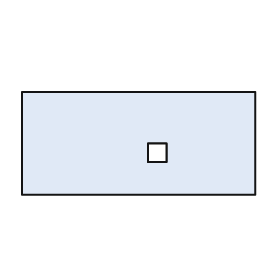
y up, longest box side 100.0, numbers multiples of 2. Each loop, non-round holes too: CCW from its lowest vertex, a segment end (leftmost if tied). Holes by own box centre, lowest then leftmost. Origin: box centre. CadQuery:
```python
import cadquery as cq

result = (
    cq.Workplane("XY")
    .moveTo(-50.0, -22.0)
    .lineTo(50.0, -22.0)
    .lineTo(50.0, 22.0)
    .lineTo(-50.0, 22.0)
    .close()
    .moveTo(4.0, -8.0)
    .lineTo(12.0, -8.0)
    .lineTo(12.0, 0.0)
    .lineTo(4.0, 0.0)
    .close()
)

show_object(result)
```